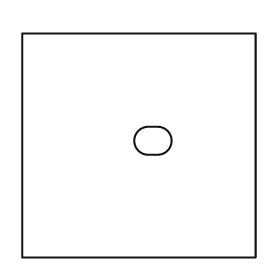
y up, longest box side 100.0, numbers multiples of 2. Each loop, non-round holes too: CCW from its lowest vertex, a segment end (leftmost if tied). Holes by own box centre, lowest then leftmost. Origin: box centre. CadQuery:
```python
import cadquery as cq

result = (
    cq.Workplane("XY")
    .moveTo(-50.0, -48.0)
    .lineTo(50.0, -48.0)
    .lineTo(50.0, 48.0)
    .lineTo(-50.0, 48.0)
    .close()
    .moveTo(4.0, -4.0)
    .lineTo(8.0, -4.0)
    .threePointArc((14.0, 2.0), (8.0, 8.0))
    .lineTo(4.0, 8.0)
    .threePointArc((-2.0, 2.0), (4.0, -4.0))
    .close()
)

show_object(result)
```